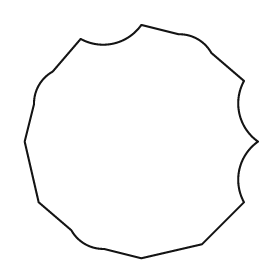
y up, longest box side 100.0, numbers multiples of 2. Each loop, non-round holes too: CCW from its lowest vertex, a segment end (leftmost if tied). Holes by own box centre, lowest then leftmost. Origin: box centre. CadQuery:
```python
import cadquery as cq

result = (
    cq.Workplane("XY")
    .moveTo(0.0, -50.0)
    .lineTo(26.0, -44.0)
    .lineTo(44.0, -26.0)
    .threePointArc((42.0, -12.0), (50.0, 0.0))
    .threePointArc((42.0, 12.0), (44.0, 26.0))
    .lineTo(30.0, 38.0)
    .threePointArc((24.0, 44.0), (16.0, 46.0))
    .lineTo(0.0, 50.0)
    .threePointArc((-12.0, 42.0), (-26.0, 44.0))
    .lineTo(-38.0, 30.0)
    .threePointArc((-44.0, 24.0), (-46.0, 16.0))
    .lineTo(-50.0, 0.0)
    .lineTo(-44.0, -26.0)
    .lineTo(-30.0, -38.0)
    .threePointArc((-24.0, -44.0), (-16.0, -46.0))
    .close()
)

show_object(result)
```